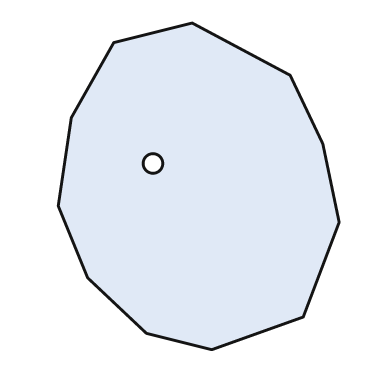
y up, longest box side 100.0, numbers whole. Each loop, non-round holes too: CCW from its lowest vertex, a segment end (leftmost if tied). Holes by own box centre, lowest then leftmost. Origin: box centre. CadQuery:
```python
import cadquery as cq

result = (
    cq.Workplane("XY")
    .moveTo(4.0, -50.0)
    .lineTo(32.0, -40.0)
    .lineTo(43.0, -11.0)
    .lineTo(38.0, 13.0)
    .lineTo(28.0, 34.0)
    .lineTo(-2.0, 50.0)
    .lineTo(-26.0, 44.0)
    .lineTo(-39.0, 21.0)
    .lineTo(-43.0, -6.0)
    .lineTo(-34.0, -28.0)
    .lineTo(-16.0, -45.0)
    .close()
    .moveTo(-14.0, 7.0)
    .circle(3.0)
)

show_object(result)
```